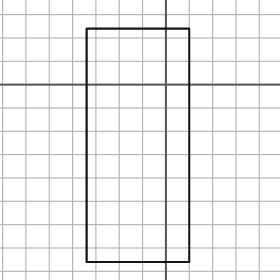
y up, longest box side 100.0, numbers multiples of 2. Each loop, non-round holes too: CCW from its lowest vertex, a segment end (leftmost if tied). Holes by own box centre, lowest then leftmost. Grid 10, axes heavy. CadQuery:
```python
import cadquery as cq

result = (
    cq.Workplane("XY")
    .moveTo(-34.0, -76.0)
    .lineTo(10.0, -76.0)
    .lineTo(10.0, 24.0)
    .lineTo(-34.0, 24.0)
    .close()
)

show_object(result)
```